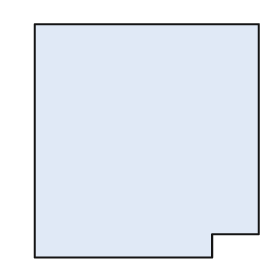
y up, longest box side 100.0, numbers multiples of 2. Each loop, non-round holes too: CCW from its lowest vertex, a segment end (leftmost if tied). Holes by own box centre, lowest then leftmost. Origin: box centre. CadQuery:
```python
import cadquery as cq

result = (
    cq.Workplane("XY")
    .moveTo(-48.0, -50.0)
    .lineTo(28.0, -50.0)
    .lineTo(28.0, -40.0)
    .lineTo(48.0, -40.0)
    .lineTo(48.0, 50.0)
    .lineTo(-48.0, 50.0)
    .close()
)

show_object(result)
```